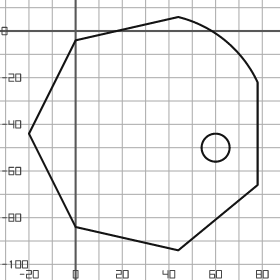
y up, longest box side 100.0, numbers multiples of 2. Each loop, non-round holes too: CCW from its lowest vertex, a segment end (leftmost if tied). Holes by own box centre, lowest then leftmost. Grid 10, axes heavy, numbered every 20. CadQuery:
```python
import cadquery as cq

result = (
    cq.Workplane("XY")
    .moveTo(44.0, -94.0)
    .lineTo(78.0, -66.0)
    .lineTo(78.0, -22.0)
    .threePointArc((64.0, -4.0), (44.0, 6.0))
    .lineTo(0.0, -4.0)
    .lineTo(-20.0, -44.0)
    .lineTo(0.0, -84.0)
    .close()
    .moveTo(60.0, -50.0)
    .circle(6.0)
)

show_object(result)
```